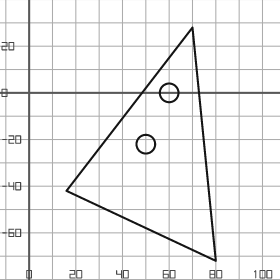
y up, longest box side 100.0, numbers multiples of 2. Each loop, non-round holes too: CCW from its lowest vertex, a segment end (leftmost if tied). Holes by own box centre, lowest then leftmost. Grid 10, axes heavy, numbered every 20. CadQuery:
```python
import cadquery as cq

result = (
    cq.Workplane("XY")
    .moveTo(80.0, -72.0)
    .lineTo(70.0, 28.0)
    .lineTo(16.0, -42.0)
    .close()
    .moveTo(50.0, -22.0)
    .circle(4.0)
    .moveTo(60.0, 0.0)
    .circle(4.0)
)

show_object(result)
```